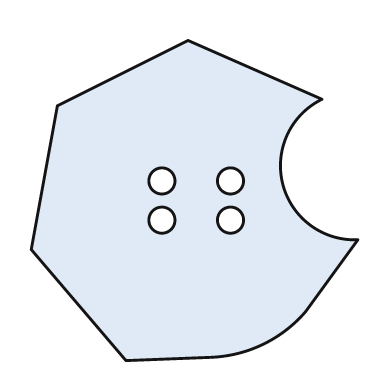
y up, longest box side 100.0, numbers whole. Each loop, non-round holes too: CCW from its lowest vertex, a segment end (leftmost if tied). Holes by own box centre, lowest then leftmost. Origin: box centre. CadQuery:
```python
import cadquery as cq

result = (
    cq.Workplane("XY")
    .moveTo(-21.0, -49.0)
    .lineTo(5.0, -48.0)
    .threePointArc((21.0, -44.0), (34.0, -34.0))
    .lineTo(50.0, -12.0)
    .threePointArc((27.0, 5.0), (39.0, 31.0))
    .lineTo(-2.0, 49.0)
    .lineTo(-42.0, 29.0)
    .lineTo(-50.0, -15.0)
    .close()
    .moveTo(-10.0, -6.0)
    .circle(4.0)
    .moveTo(11.0, -6.0)
    .circle(4.0)
    .moveTo(-10.0, 6.0)
    .circle(4.0)
    .moveTo(11.0, 6.0)
    .circle(4.0)
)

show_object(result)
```